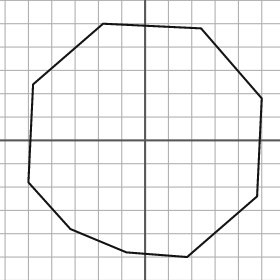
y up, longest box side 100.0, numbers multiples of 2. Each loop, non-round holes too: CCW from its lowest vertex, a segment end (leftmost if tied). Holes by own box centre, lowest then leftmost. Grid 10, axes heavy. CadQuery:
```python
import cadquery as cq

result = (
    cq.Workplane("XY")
    .moveTo(18.0, -50.0)
    .lineTo(48.0, -24.0)
    .lineTo(50.0, 18.0)
    .lineTo(24.0, 48.0)
    .lineTo(-18.0, 50.0)
    .lineTo(-48.0, 24.0)
    .lineTo(-50.0, -18.0)
    .lineTo(-32.0, -38.0)
    .lineTo(-8.0, -48.0)
    .close()
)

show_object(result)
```